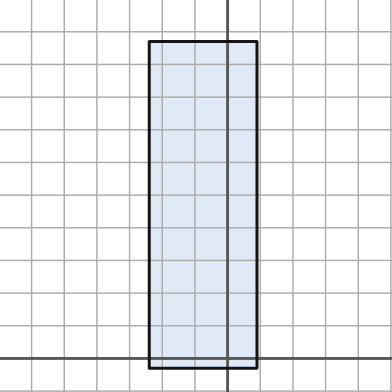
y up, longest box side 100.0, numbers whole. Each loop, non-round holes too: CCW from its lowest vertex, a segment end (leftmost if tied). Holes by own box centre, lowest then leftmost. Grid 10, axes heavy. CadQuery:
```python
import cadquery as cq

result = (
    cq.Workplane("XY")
    .moveTo(-24.0, -3.0)
    .lineTo(9.0, -3.0)
    .lineTo(9.0, 97.0)
    .lineTo(-24.0, 97.0)
    .close()
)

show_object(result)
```